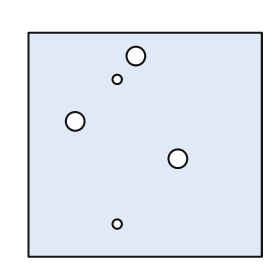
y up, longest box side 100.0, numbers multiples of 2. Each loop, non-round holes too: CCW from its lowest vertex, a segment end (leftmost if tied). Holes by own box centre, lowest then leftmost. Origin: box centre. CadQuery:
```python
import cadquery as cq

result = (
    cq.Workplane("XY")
    .moveTo(-50.0, -48.0)
    .lineTo(50.0, -48.0)
    .lineTo(50.0, 48.0)
    .lineTo(-50.0, 48.0)
    .close()
    .moveTo(-12.0, -34.0)
    .circle(2.0)
    .moveTo(14.0, -6.0)
    .circle(4.0)
    .moveTo(-30.0, 10.0)
    .circle(4.0)
    .moveTo(-12.0, 28.0)
    .circle(2.0)
    .moveTo(-4.0, 38.0)
    .circle(4.0)
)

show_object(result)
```